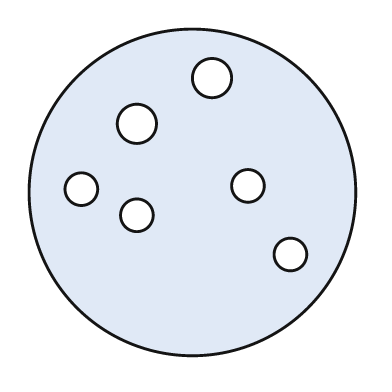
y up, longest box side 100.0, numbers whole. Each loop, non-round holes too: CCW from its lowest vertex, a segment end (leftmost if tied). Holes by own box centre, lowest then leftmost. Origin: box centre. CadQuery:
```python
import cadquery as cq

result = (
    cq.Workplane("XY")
    .moveTo(0.0, 0.0)
    .circle(50.0)
    .moveTo(30.0, -19.0)
    .circle(5.0)
    .moveTo(-17.0, -7.0)
    .circle(5.0)
    .moveTo(-34.0, 1.0)
    .circle(5.0)
    .moveTo(17.0, 2.0)
    .circle(5.0)
    .moveTo(-17.0, 21.0)
    .circle(6.0)
    .moveTo(6.0, 35.0)
    .circle(6.0)
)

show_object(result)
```